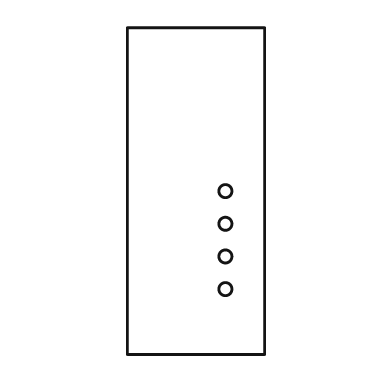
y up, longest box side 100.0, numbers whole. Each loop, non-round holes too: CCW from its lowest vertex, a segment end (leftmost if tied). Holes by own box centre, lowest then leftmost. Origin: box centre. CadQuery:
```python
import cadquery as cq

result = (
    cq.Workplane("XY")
    .moveTo(-21.0, -50.0)
    .lineTo(21.0, -50.0)
    .lineTo(21.0, 50.0)
    .lineTo(-21.0, 50.0)
    .close()
    .moveTo(9.0, -30.0)
    .circle(2.0)
    .moveTo(9.0, -20.0)
    .circle(2.0)
    .moveTo(9.0, -10.0)
    .circle(2.0)
    .moveTo(9.0, 0.0)
    .circle(2.0)
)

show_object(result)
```